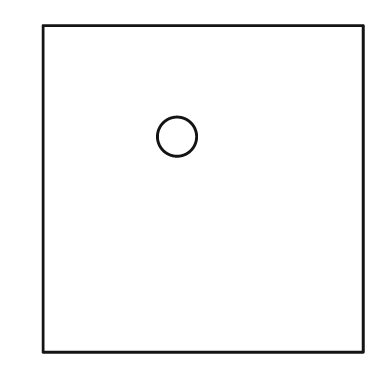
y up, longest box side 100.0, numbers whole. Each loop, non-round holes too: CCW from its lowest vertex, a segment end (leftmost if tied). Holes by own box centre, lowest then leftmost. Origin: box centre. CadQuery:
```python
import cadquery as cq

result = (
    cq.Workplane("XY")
    .moveTo(-49.0, -50.0)
    .lineTo(49.0, -50.0)
    .lineTo(49.0, 50.0)
    .lineTo(-49.0, 50.0)
    .close()
    .moveTo(-8.0, 16.0)
    .circle(6.0)
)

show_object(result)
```